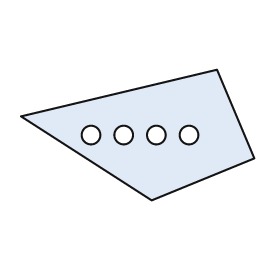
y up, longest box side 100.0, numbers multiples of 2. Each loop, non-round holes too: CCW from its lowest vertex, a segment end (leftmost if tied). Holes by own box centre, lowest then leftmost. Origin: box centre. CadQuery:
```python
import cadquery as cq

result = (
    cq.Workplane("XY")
    .moveTo(6.0, -28.0)
    .lineTo(50.0, -10.0)
    .lineTo(34.0, 28.0)
    .lineTo(-50.0, 8.0)
    .close()
    .moveTo(-20.0, 0.0)
    .circle(4.0)
    .moveTo(-6.0, 0.0)
    .circle(4.0)
    .moveTo(8.0, 0.0)
    .circle(4.0)
    .moveTo(22.0, 0.0)
    .circle(4.0)
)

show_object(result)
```